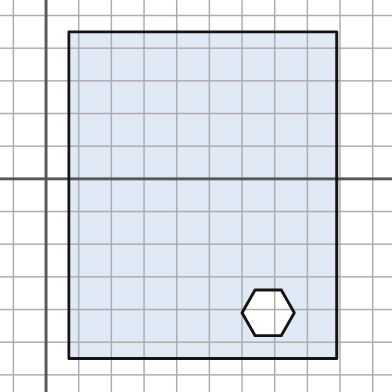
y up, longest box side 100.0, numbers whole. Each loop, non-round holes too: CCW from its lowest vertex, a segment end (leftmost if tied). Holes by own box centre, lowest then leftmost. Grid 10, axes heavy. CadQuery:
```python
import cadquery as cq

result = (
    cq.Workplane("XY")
    .moveTo(7.0, -55.0)
    .lineTo(89.0, -55.0)
    .lineTo(89.0, 45.0)
    .lineTo(7.0, 45.0)
    .close()
    .moveTo(64.0, -48.0)
    .lineTo(72.0, -48.0)
    .lineTo(76.0, -41.0)
    .lineTo(72.0, -34.0)
    .lineTo(64.0, -34.0)
    .lineTo(60.0, -41.0)
    .close()
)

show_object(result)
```